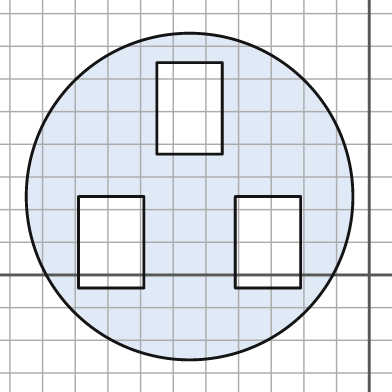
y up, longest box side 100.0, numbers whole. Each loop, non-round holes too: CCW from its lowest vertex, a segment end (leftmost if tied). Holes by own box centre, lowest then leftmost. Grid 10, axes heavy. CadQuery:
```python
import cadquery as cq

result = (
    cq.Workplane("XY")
    .moveTo(-55.0, 24.0)
    .circle(50.0)
    .moveTo(-89.0, -4.0)
    .lineTo(-69.0, -4.0)
    .lineTo(-69.0, 24.0)
    .lineTo(-89.0, 24.0)
    .close()
    .moveTo(-41.0, -4.0)
    .lineTo(-21.0, -4.0)
    .lineTo(-21.0, 24.0)
    .lineTo(-41.0, 24.0)
    .close()
    .moveTo(-65.0, 37.0)
    .lineTo(-45.0, 37.0)
    .lineTo(-45.0, 65.0)
    .lineTo(-65.0, 65.0)
    .close()
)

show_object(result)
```